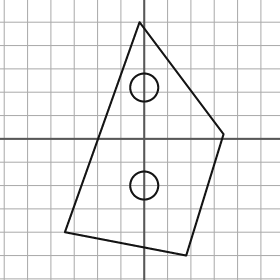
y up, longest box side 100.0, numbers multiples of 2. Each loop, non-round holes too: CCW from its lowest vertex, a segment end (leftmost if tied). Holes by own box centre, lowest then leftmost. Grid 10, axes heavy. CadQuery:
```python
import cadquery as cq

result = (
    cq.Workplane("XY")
    .moveTo(18.0, -50.0)
    .lineTo(34.0, 2.0)
    .lineTo(-2.0, 50.0)
    .lineTo(-34.0, -40.0)
    .close()
    .moveTo(0.0, -20.0)
    .circle(6.0)
    .moveTo(0.0, 22.0)
    .circle(6.0)
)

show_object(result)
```